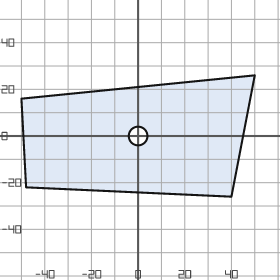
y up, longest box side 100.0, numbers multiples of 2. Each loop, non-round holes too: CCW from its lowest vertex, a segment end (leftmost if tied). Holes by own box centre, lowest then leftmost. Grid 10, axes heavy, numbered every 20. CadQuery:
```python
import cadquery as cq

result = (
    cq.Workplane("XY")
    .moveTo(40.0, -26.0)
    .lineTo(50.0, 26.0)
    .lineTo(-50.0, 16.0)
    .lineTo(-48.0, -22.0)
    .close()
    .moveTo(0.0, 0.0)
    .circle(4.0)
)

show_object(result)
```